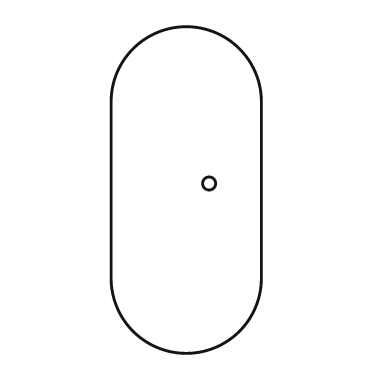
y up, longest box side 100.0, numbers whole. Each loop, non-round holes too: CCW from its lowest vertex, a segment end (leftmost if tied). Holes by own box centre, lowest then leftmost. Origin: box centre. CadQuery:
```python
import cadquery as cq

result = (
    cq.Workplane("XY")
    .moveTo(-23.0, -27.0)
    .threePointArc((0.0, -50.0), (23.0, -27.0))
    .lineTo(23.0, 27.0)
    .threePointArc((0.0, 50.0), (-23.0, 27.0))
    .close()
    .moveTo(7.0, 2.0)
    .circle(2.0)
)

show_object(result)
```